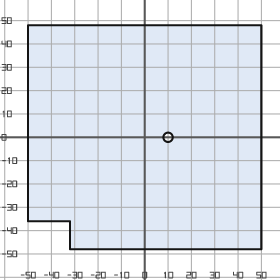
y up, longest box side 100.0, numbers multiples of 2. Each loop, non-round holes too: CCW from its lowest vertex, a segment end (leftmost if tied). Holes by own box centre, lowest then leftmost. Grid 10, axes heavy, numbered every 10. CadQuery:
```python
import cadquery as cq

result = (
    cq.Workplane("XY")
    .moveTo(-32.0, -48.0)
    .lineTo(50.0, -48.0)
    .lineTo(50.0, 48.0)
    .lineTo(-50.0, 48.0)
    .lineTo(-50.0, -36.0)
    .lineTo(-32.0, -36.0)
    .close()
    .moveTo(10.0, 0.0)
    .circle(2.0)
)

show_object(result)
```